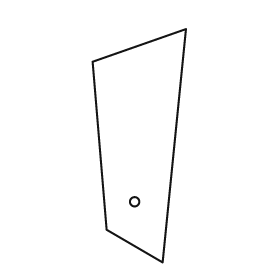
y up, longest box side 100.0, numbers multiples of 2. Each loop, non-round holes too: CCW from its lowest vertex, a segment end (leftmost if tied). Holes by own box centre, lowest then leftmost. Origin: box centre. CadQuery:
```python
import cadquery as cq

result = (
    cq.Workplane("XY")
    .moveTo(10.0, -50.0)
    .lineTo(20.0, 50.0)
    .lineTo(-20.0, 36.0)
    .lineTo(-14.0, -36.0)
    .close()
    .moveTo(-2.0, -24.0)
    .circle(2.0)
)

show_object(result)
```